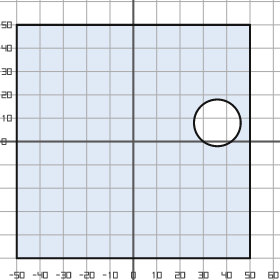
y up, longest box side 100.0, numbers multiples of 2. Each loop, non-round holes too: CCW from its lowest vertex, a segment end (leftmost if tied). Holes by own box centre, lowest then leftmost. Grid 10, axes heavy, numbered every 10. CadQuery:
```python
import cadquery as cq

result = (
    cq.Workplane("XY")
    .moveTo(-50.0, -50.0)
    .lineTo(50.0, -50.0)
    .lineTo(50.0, 50.0)
    .lineTo(-50.0, 50.0)
    .close()
    .moveTo(36.0, 8.0)
    .circle(10.0)
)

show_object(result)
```